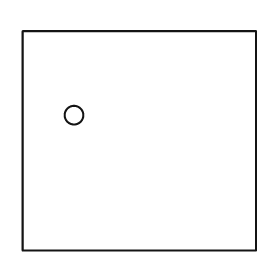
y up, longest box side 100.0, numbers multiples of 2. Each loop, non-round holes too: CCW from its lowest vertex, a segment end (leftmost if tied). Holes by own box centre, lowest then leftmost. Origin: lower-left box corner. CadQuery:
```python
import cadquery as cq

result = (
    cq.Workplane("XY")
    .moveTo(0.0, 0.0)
    .lineTo(100.0, 0.0)
    .lineTo(100.0, 94.0)
    .lineTo(0.0, 94.0)
    .close()
    .moveTo(22.0, 58.0)
    .circle(4.0)
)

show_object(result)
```